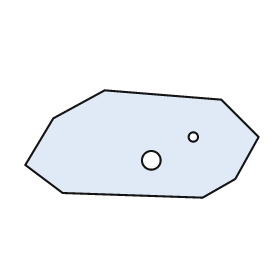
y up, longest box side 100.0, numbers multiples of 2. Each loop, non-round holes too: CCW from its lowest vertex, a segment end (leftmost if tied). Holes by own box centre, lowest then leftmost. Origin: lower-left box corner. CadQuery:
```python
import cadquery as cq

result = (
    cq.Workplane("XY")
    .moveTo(76.0, 0.0)
    .lineTo(90.0, 8.0)
    .lineTo(100.0, 26.0)
    .lineTo(84.0, 42.0)
    .lineTo(34.0, 46.0)
    .lineTo(12.0, 34.0)
    .lineTo(0.0, 14.0)
    .lineTo(16.0, 2.0)
    .close()
    .moveTo(54.0, 16.0)
    .circle(4.0)
    .moveTo(72.0, 26.0)
    .circle(2.0)
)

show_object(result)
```